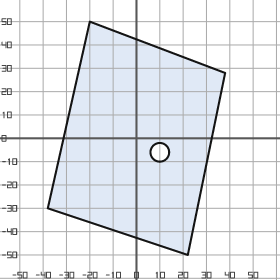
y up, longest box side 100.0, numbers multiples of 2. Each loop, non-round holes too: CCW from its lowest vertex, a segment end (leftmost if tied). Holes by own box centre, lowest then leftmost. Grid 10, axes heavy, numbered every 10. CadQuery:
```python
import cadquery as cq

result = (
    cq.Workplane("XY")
    .moveTo(22.0, -50.0)
    .lineTo(38.0, 28.0)
    .lineTo(-20.0, 50.0)
    .lineTo(-38.0, -30.0)
    .close()
    .moveTo(10.0, -6.0)
    .circle(4.0)
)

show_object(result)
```